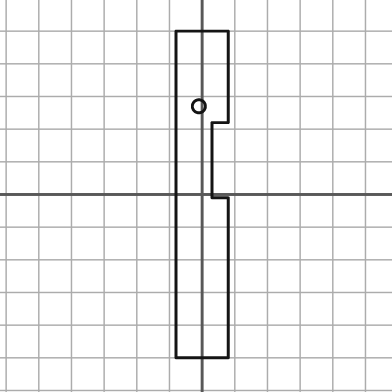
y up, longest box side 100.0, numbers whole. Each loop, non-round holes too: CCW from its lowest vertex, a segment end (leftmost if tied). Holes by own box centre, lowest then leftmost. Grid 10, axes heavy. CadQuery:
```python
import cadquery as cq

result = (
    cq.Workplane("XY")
    .moveTo(-8.0, -50.0)
    .lineTo(8.0, -50.0)
    .lineTo(8.0, -1.0)
    .lineTo(3.0, -1.0)
    .lineTo(3.0, 22.0)
    .lineTo(8.0, 22.0)
    .lineTo(8.0, 50.0)
    .lineTo(-8.0, 50.0)
    .close()
    .moveTo(-1.0, 27.0)
    .circle(2.0)
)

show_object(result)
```